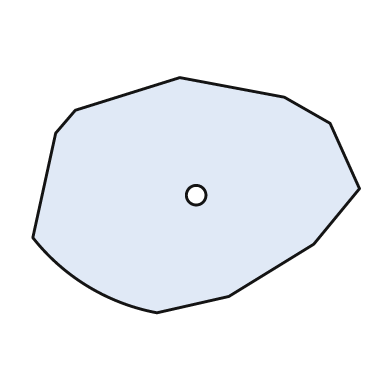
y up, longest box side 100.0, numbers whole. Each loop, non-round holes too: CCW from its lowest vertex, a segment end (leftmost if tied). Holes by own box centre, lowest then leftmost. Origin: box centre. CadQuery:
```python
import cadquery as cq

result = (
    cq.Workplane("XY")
    .moveTo(-12.0, -36.0)
    .lineTo(10.0, -31.0)
    .lineTo(36.0, -15.0)
    .lineTo(50.0, 2.0)
    .lineTo(41.0, 22.0)
    .lineTo(27.0, 30.0)
    .lineTo(-5.0, 36.0)
    .lineTo(-37.0, 26.0)
    .lineTo(-43.0, 19.0)
    .lineTo(-50.0, -13.0)
    .threePointArc((-33.0, -28.0), (-12.0, -36.0))
    .close()
    .moveTo(0.0, 0.0)
    .circle(3.0)
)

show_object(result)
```